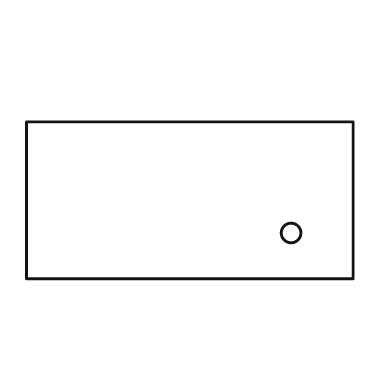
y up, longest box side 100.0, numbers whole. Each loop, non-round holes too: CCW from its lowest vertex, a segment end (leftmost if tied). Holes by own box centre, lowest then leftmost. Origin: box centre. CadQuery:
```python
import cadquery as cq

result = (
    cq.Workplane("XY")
    .moveTo(-50.0, -24.0)
    .lineTo(50.0, -24.0)
    .lineTo(50.0, 24.0)
    .lineTo(-50.0, 24.0)
    .close()
    .moveTo(31.0, -10.0)
    .circle(3.0)
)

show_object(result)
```